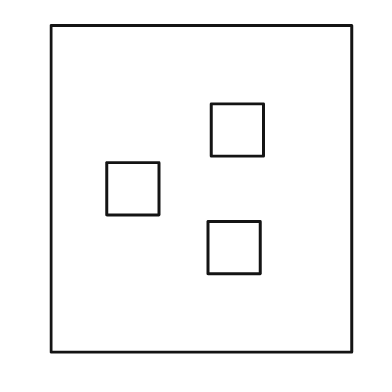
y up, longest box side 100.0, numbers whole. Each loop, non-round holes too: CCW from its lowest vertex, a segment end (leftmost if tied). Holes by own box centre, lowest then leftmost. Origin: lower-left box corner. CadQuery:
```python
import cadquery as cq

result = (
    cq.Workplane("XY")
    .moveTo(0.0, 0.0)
    .lineTo(92.0, 0.0)
    .lineTo(92.0, 100.0)
    .lineTo(0.0, 100.0)
    .close()
    .moveTo(48.0, 24.0)
    .lineTo(64.0, 24.0)
    .lineTo(64.0, 40.0)
    .lineTo(48.0, 40.0)
    .close()
    .moveTo(17.0, 42.0)
    .lineTo(33.0, 42.0)
    .lineTo(33.0, 58.0)
    .lineTo(17.0, 58.0)
    .close()
    .moveTo(49.0, 60.0)
    .lineTo(65.0, 60.0)
    .lineTo(65.0, 76.0)
    .lineTo(49.0, 76.0)
    .close()
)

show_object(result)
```